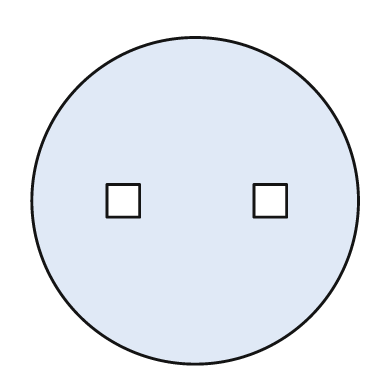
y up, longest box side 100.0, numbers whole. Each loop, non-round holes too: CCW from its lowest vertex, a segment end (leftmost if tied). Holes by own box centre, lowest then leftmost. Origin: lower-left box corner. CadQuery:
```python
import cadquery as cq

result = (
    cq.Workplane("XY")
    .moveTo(50.0, 50.0)
    .circle(50.0)
    .moveTo(23.0, 45.0)
    .lineTo(33.0, 45.0)
    .lineTo(33.0, 55.0)
    .lineTo(23.0, 55.0)
    .close()
    .moveTo(68.0, 45.0)
    .lineTo(78.0, 45.0)
    .lineTo(78.0, 55.0)
    .lineTo(68.0, 55.0)
    .close()
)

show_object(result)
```